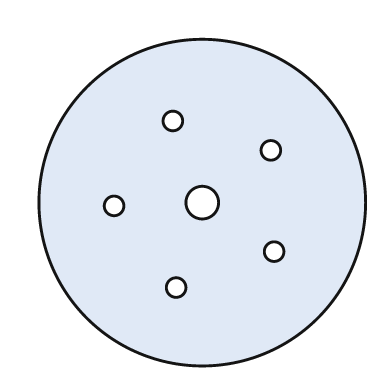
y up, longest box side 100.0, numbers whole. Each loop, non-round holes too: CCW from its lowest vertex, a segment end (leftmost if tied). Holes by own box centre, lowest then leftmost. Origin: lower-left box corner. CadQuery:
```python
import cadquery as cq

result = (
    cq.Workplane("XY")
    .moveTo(50.0, 50.0)
    .circle(50.0)
    .moveTo(42.0, 24.0)
    .circle(3.0)
    .moveTo(72.0, 35.0)
    .circle(3.0)
    .moveTo(23.0, 49.0)
    .circle(3.0)
    .moveTo(50.0, 50.0)
    .circle(5.0)
    .moveTo(71.0, 66.0)
    .circle(3.0)
    .moveTo(41.0, 75.0)
    .circle(3.0)
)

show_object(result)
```